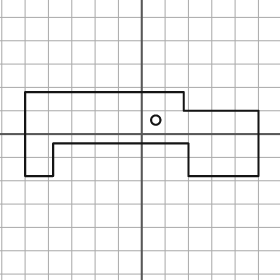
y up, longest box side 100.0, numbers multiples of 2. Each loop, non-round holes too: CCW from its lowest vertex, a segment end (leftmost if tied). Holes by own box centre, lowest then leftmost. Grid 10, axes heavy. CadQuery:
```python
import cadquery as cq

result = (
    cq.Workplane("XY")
    .moveTo(-50.0, -18.0)
    .lineTo(-38.0, -18.0)
    .lineTo(-38.0, -4.0)
    .lineTo(20.0, -4.0)
    .lineTo(20.0, -18.0)
    .lineTo(50.0, -18.0)
    .lineTo(50.0, 10.0)
    .lineTo(18.0, 10.0)
    .lineTo(18.0, 18.0)
    .lineTo(-50.0, 18.0)
    .close()
    .moveTo(6.0, 6.0)
    .circle(2.0)
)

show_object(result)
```